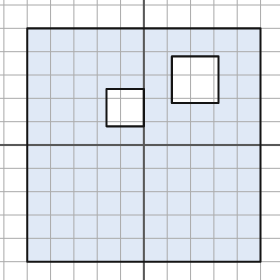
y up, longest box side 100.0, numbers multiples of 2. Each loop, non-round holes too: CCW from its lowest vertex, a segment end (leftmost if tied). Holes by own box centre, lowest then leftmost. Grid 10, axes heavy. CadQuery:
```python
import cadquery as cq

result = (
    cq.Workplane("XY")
    .moveTo(-50.0, -50.0)
    .lineTo(50.0, -50.0)
    .lineTo(50.0, 50.0)
    .lineTo(-50.0, 50.0)
    .close()
    .moveTo(-16.0, 8.0)
    .lineTo(0.0, 8.0)
    .lineTo(0.0, 24.0)
    .lineTo(-16.0, 24.0)
    .close()
    .moveTo(12.0, 18.0)
    .lineTo(32.0, 18.0)
    .lineTo(32.0, 38.0)
    .lineTo(12.0, 38.0)
    .close()
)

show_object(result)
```